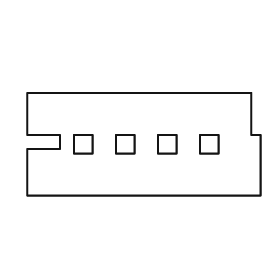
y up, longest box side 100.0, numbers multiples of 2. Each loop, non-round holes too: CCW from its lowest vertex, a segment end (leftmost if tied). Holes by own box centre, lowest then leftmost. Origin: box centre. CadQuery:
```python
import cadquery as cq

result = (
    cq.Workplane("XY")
    .moveTo(-50.0, -22.0)
    .lineTo(50.0, -22.0)
    .lineTo(50.0, 4.0)
    .lineTo(46.0, 4.0)
    .lineTo(46.0, 22.0)
    .lineTo(-50.0, 22.0)
    .lineTo(-50.0, 4.0)
    .lineTo(-36.0, 4.0)
    .lineTo(-36.0, -2.0)
    .lineTo(-50.0, -2.0)
    .close()
    .moveTo(-30.0, -4.0)
    .lineTo(-22.0, -4.0)
    .lineTo(-22.0, 4.0)
    .lineTo(-30.0, 4.0)
    .close()
    .moveTo(-12.0, -4.0)
    .lineTo(-4.0, -4.0)
    .lineTo(-4.0, 4.0)
    .lineTo(-12.0, 4.0)
    .close()
    .moveTo(6.0, -4.0)
    .lineTo(14.0, -4.0)
    .lineTo(14.0, 4.0)
    .lineTo(6.0, 4.0)
    .close()
    .moveTo(24.0, -4.0)
    .lineTo(32.0, -4.0)
    .lineTo(32.0, 4.0)
    .lineTo(24.0, 4.0)
    .close()
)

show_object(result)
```